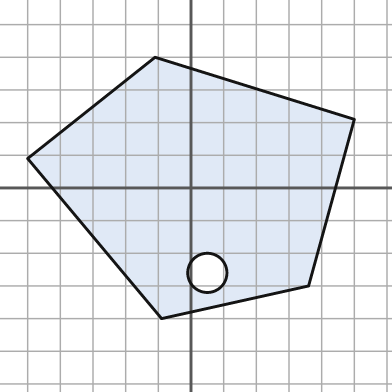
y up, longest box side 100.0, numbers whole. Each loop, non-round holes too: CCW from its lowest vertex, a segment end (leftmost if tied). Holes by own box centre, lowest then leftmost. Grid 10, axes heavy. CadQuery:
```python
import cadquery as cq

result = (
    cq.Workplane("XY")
    .moveTo(-9.0, -40.0)
    .lineTo(36.0, -30.0)
    .lineTo(50.0, 21.0)
    .lineTo(-11.0, 40.0)
    .lineTo(-50.0, 9.0)
    .close()
    .moveTo(5.0, -26.0)
    .circle(6.0)
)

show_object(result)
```